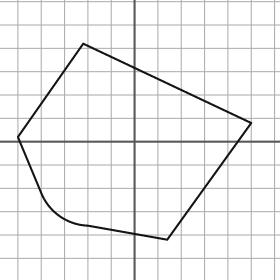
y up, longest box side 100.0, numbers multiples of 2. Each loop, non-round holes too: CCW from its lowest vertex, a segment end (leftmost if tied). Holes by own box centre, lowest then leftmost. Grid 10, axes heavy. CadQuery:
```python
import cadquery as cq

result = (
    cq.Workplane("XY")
    .moveTo(14.0, -42.0)
    .lineTo(50.0, 8.0)
    .lineTo(-22.0, 42.0)
    .lineTo(-50.0, 2.0)
    .lineTo(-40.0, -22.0)
    .threePointArc((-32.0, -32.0), (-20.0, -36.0))
    .close()
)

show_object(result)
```